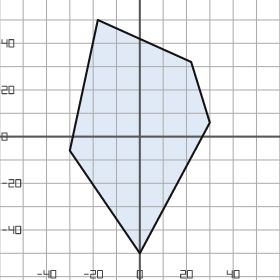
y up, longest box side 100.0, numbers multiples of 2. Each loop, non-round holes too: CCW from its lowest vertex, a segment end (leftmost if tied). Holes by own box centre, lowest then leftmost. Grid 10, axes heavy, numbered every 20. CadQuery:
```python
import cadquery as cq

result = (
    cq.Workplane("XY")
    .moveTo(0.0, -50.0)
    .lineTo(30.0, 6.0)
    .lineTo(22.0, 32.0)
    .lineTo(-18.0, 50.0)
    .lineTo(-30.0, -6.0)
    .close()
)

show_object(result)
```